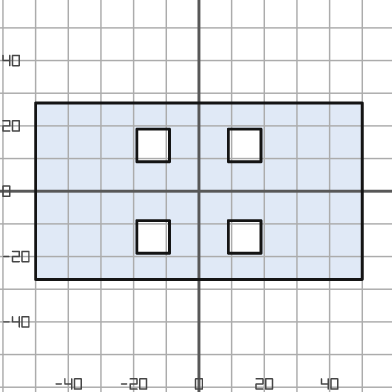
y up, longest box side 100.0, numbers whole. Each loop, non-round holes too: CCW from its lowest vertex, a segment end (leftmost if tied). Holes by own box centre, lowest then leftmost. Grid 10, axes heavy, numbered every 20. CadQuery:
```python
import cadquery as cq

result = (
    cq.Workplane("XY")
    .moveTo(-50.0, -27.0)
    .lineTo(50.0, -27.0)
    .lineTo(50.0, 27.0)
    .lineTo(-50.0, 27.0)
    .close()
    .moveTo(-19.0, -19.0)
    .lineTo(-9.0, -19.0)
    .lineTo(-9.0, -9.0)
    .lineTo(-19.0, -9.0)
    .close()
    .moveTo(9.0, -19.0)
    .lineTo(19.0, -19.0)
    .lineTo(19.0, -9.0)
    .lineTo(9.0, -9.0)
    .close()
    .moveTo(-19.0, 9.0)
    .lineTo(-9.0, 9.0)
    .lineTo(-9.0, 19.0)
    .lineTo(-19.0, 19.0)
    .close()
    .moveTo(9.0, 9.0)
    .lineTo(19.0, 9.0)
    .lineTo(19.0, 19.0)
    .lineTo(9.0, 19.0)
    .close()
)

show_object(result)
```